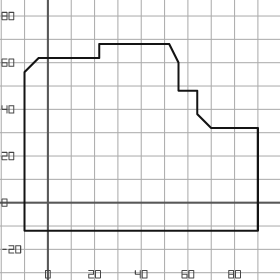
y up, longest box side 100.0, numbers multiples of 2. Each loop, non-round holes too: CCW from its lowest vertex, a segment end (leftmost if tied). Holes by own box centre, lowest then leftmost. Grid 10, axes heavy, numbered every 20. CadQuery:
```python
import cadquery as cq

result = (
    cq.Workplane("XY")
    .moveTo(-10.0, -12.0)
    .lineTo(90.0, -12.0)
    .lineTo(90.0, 32.0)
    .lineTo(70.0, 32.0)
    .lineTo(64.0, 38.0)
    .lineTo(64.0, 48.0)
    .lineTo(56.0, 48.0)
    .lineTo(56.0, 60.0)
    .lineTo(52.0, 68.0)
    .lineTo(22.0, 68.0)
    .lineTo(22.0, 62.0)
    .lineTo(-4.0, 62.0)
    .lineTo(-10.0, 56.0)
    .close()
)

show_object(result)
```